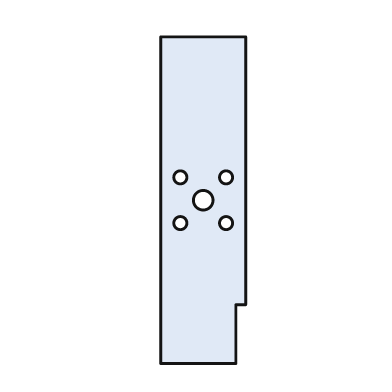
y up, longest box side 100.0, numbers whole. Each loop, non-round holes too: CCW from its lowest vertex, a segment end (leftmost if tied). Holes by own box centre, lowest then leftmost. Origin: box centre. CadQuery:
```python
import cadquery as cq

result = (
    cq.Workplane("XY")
    .moveTo(-13.0, -50.0)
    .lineTo(10.0, -50.0)
    .lineTo(10.0, -32.0)
    .lineTo(13.0, -32.0)
    .lineTo(13.0, 50.0)
    .lineTo(-13.0, 50.0)
    .close()
    .moveTo(-7.0, -7.0)
    .circle(2.0)
    .moveTo(7.0, -7.0)
    .circle(2.0)
    .moveTo(0.0, 0.0)
    .circle(3.0)
    .moveTo(-7.0, 7.0)
    .circle(2.0)
    .moveTo(7.0, 7.0)
    .circle(2.0)
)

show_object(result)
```